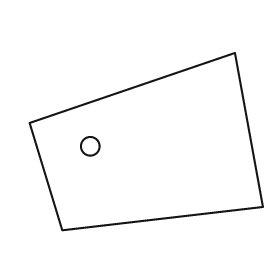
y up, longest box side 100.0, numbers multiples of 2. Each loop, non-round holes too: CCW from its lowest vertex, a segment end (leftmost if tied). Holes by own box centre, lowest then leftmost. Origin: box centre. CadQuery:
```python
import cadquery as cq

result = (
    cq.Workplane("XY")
    .moveTo(-36.0, -38.0)
    .lineTo(50.0, -28.0)
    .lineTo(38.0, 38.0)
    .lineTo(-50.0, 8.0)
    .close()
    .moveTo(-24.0, -2.0)
    .circle(4.0)
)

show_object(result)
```